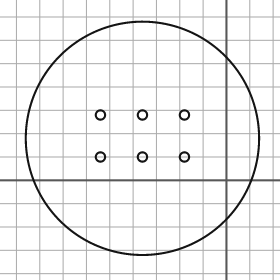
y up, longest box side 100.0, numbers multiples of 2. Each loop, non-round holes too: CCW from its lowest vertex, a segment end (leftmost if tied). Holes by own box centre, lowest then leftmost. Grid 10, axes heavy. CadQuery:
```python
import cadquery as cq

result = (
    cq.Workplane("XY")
    .moveTo(-36.0, 18.0)
    .circle(50.0)
    .moveTo(-54.0, 10.0)
    .circle(2.0)
    .moveTo(-36.0, 10.0)
    .circle(2.0)
    .moveTo(-18.0, 10.0)
    .circle(2.0)
    .moveTo(-54.0, 28.0)
    .circle(2.0)
    .moveTo(-36.0, 28.0)
    .circle(2.0)
    .moveTo(-18.0, 28.0)
    .circle(2.0)
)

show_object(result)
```